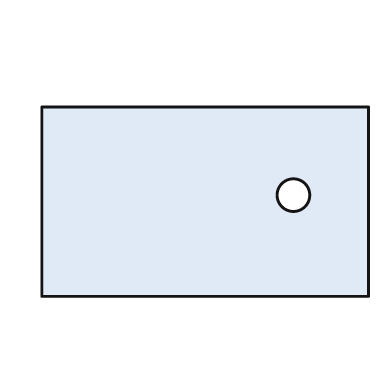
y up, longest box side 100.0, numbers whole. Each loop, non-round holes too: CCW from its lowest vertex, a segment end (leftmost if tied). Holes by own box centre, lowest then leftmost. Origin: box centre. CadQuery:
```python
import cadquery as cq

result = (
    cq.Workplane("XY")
    .moveTo(-50.0, -29.0)
    .lineTo(50.0, -29.0)
    .lineTo(50.0, 29.0)
    .lineTo(-50.0, 29.0)
    .close()
    .moveTo(27.0, 2.0)
    .circle(5.0)
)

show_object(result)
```